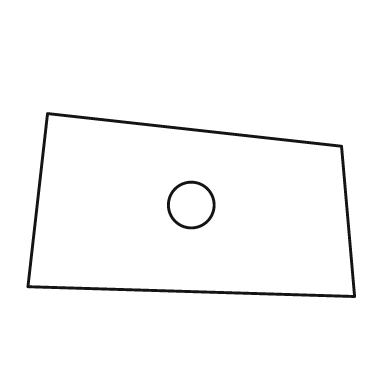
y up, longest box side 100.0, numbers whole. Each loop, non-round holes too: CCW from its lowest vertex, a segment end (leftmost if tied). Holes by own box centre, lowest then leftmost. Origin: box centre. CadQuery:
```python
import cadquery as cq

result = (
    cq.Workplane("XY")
    .moveTo(50.0, -28.0)
    .lineTo(46.0, 18.0)
    .lineTo(-44.0, 28.0)
    .lineTo(-50.0, -25.0)
    .close()
    .moveTo(0.0, 0.0)
    .circle(7.0)
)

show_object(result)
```